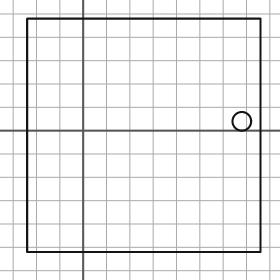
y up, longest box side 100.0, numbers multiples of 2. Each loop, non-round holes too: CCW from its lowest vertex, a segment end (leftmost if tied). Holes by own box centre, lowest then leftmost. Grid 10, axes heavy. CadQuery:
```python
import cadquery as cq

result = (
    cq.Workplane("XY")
    .moveTo(-24.0, -52.0)
    .lineTo(76.0, -52.0)
    .lineTo(76.0, 48.0)
    .lineTo(-24.0, 48.0)
    .close()
    .moveTo(68.0, 4.0)
    .circle(4.0)
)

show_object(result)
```